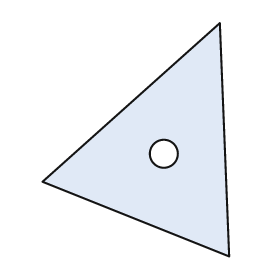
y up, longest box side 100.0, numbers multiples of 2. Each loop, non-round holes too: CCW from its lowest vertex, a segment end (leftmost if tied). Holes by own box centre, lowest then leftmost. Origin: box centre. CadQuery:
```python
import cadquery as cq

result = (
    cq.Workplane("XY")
    .moveTo(40.0, -50.0)
    .lineTo(36.0, 50.0)
    .lineTo(-40.0, -18.0)
    .close()
    .moveTo(12.0, -6.0)
    .circle(6.0)
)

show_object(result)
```